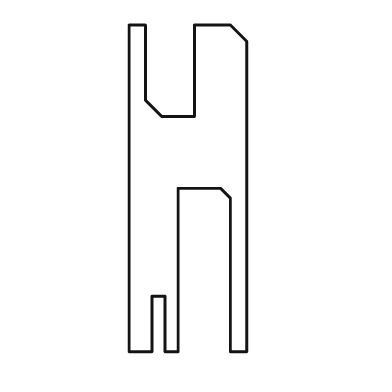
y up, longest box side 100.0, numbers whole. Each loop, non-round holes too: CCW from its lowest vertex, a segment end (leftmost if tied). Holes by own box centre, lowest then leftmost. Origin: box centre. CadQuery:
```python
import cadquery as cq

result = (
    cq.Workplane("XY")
    .moveTo(-18.0, -50.0)
    .lineTo(-11.0, -50.0)
    .lineTo(-11.0, -33.0)
    .lineTo(-7.0, -33.0)
    .lineTo(-7.0, -50.0)
    .lineTo(-3.0, -50.0)
    .lineTo(-3.0, 0.0)
    .lineTo(10.0, 0.0)
    .lineTo(13.0, -3.0)
    .lineTo(13.0, -50.0)
    .lineTo(18.0, -50.0)
    .lineTo(18.0, 45.0)
    .lineTo(13.0, 50.0)
    .lineTo(2.0, 50.0)
    .lineTo(2.0, 22.0)
    .lineTo(-8.0, 22.0)
    .lineTo(-13.0, 27.0)
    .lineTo(-13.0, 50.0)
    .lineTo(-18.0, 50.0)
    .close()
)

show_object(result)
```